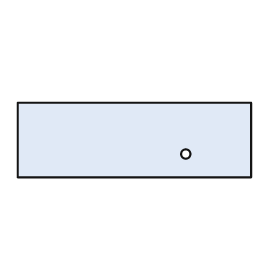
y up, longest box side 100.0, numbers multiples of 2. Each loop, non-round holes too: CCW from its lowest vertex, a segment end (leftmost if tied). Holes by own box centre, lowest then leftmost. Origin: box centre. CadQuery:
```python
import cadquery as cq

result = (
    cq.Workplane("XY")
    .moveTo(-50.0, -16.0)
    .lineTo(50.0, -16.0)
    .lineTo(50.0, 16.0)
    .lineTo(-50.0, 16.0)
    .close()
    .moveTo(22.0, -6.0)
    .circle(2.0)
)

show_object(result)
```